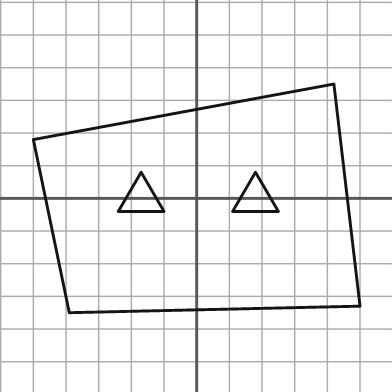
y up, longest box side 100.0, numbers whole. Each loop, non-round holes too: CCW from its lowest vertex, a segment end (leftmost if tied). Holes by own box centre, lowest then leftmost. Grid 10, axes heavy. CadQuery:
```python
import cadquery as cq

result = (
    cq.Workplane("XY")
    .moveTo(-39.0, -35.0)
    .lineTo(50.0, -33.0)
    .lineTo(42.0, 35.0)
    .lineTo(-50.0, 18.0)
    .close()
    .moveTo(-24.0, -4.0)
    .lineTo(-10.0, -4.0)
    .lineTo(-17.0, 8.0)
    .close()
    .moveTo(11.0, -4.0)
    .lineTo(25.0, -4.0)
    .lineTo(18.0, 8.0)
    .close()
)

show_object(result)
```